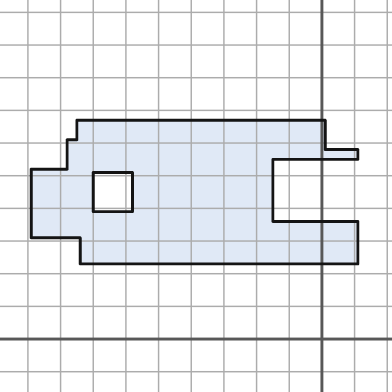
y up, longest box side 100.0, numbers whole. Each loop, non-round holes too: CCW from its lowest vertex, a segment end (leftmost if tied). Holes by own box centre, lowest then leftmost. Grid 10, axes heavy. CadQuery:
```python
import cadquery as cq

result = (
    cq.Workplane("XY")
    .moveTo(-74.0, 23.0)
    .lineTo(11.0, 23.0)
    .lineTo(11.0, 36.0)
    .lineTo(-15.0, 36.0)
    .lineTo(-15.0, 55.0)
    .lineTo(11.0, 55.0)
    .lineTo(11.0, 58.0)
    .lineTo(1.0, 58.0)
    .lineTo(1.0, 67.0)
    .lineTo(-75.0, 67.0)
    .lineTo(-75.0, 61.0)
    .lineTo(-78.0, 61.0)
    .lineTo(-78.0, 52.0)
    .lineTo(-89.0, 52.0)
    .lineTo(-89.0, 31.0)
    .lineTo(-74.0, 31.0)
    .close()
    .moveTo(-70.0, 39.0)
    .lineTo(-58.0, 39.0)
    .lineTo(-58.0, 51.0)
    .lineTo(-70.0, 51.0)
    .close()
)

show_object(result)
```